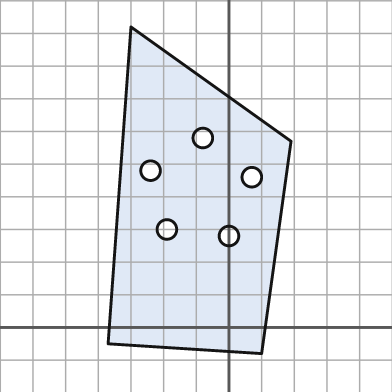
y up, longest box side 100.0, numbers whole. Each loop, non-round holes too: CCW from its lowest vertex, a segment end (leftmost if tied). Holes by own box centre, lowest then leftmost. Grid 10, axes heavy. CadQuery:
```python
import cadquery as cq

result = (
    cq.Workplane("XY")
    .moveTo(10.0, -8.0)
    .lineTo(19.0, 57.0)
    .lineTo(-30.0, 92.0)
    .lineTo(-37.0, -5.0)
    .close()
    .moveTo(0.0, 28.0)
    .circle(3.0)
    .moveTo(-19.0, 30.0)
    .circle(3.0)
    .moveTo(7.0, 46.0)
    .circle(3.0)
    .moveTo(-24.0, 48.0)
    .circle(3.0)
    .moveTo(-8.0, 58.0)
    .circle(3.0)
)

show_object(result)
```